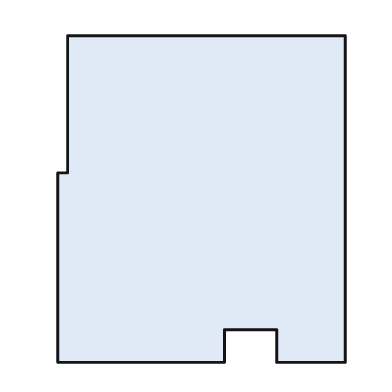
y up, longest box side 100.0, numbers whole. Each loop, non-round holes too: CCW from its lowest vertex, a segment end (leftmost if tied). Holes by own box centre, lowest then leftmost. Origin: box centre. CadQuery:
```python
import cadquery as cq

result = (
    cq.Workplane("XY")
    .moveTo(-44.0, -50.0)
    .lineTo(7.0, -50.0)
    .lineTo(7.0, -40.0)
    .lineTo(23.0, -40.0)
    .lineTo(23.0, -50.0)
    .lineTo(44.0, -50.0)
    .lineTo(44.0, 50.0)
    .lineTo(-41.0, 50.0)
    .lineTo(-41.0, 8.0)
    .lineTo(-44.0, 8.0)
    .close()
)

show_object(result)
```